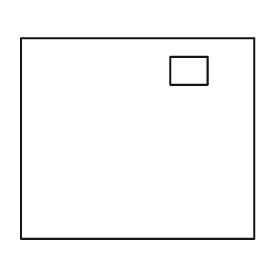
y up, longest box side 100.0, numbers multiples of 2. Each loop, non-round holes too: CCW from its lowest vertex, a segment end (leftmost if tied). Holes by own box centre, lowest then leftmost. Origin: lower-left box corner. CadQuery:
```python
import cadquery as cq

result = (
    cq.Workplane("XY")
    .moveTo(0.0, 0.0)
    .lineTo(100.0, 0.0)
    .lineTo(100.0, 86.0)
    .lineTo(0.0, 86.0)
    .close()
    .moveTo(64.0, 66.0)
    .lineTo(80.0, 66.0)
    .lineTo(80.0, 78.0)
    .lineTo(64.0, 78.0)
    .close()
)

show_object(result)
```